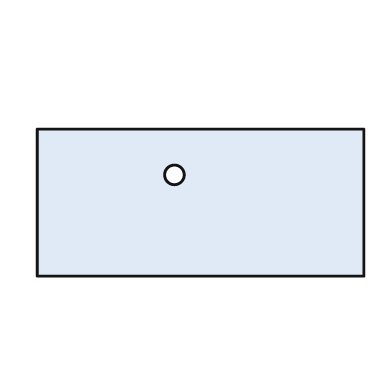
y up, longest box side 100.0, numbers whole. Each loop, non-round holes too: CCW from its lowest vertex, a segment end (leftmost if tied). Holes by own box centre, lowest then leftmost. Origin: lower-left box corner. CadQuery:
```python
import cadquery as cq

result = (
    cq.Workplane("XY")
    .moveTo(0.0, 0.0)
    .lineTo(100.0, 0.0)
    .lineTo(100.0, 45.0)
    .lineTo(0.0, 45.0)
    .close()
    .moveTo(42.0, 31.0)
    .circle(3.0)
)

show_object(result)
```